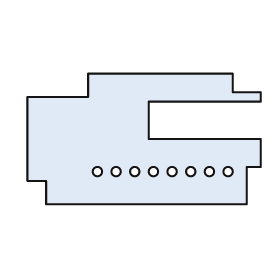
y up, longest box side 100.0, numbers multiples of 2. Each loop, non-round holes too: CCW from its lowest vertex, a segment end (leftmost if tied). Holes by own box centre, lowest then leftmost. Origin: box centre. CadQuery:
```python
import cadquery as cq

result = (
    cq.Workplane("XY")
    .moveTo(-42.0, -28.0)
    .lineTo(44.0, -28.0)
    .lineTo(44.0, -12.0)
    .lineTo(50.0, -12.0)
    .lineTo(50.0, 0.0)
    .lineTo(2.0, 0.0)
    .lineTo(2.0, 16.0)
    .lineTo(50.0, 16.0)
    .lineTo(50.0, 20.0)
    .lineTo(38.0, 20.0)
    .lineTo(38.0, 28.0)
    .lineTo(-24.0, 28.0)
    .lineTo(-24.0, 18.0)
    .lineTo(-50.0, 18.0)
    .lineTo(-50.0, -18.0)
    .lineTo(-42.0, -18.0)
    .close()
    .moveTo(-20.0, -14.0)
    .circle(2.0)
    .moveTo(-12.0, -14.0)
    .circle(2.0)
    .moveTo(-4.0, -14.0)
    .circle(2.0)
    .moveTo(4.0, -14.0)
    .circle(2.0)
    .moveTo(12.0, -14.0)
    .circle(2.0)
    .moveTo(20.0, -14.0)
    .circle(2.0)
    .moveTo(28.0, -14.0)
    .circle(2.0)
    .moveTo(36.0, -14.0)
    .circle(2.0)
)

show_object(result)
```